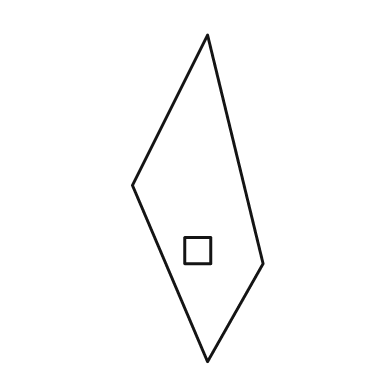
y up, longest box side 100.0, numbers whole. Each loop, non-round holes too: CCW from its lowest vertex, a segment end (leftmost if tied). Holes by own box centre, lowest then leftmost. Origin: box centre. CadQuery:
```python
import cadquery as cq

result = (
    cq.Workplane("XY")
    .moveTo(3.0, -50.0)
    .lineTo(20.0, -20.0)
    .lineTo(3.0, 50.0)
    .lineTo(-20.0, 4.0)
    .close()
    .moveTo(-4.0, -20.0)
    .lineTo(4.0, -20.0)
    .lineTo(4.0, -12.0)
    .lineTo(-4.0, -12.0)
    .close()
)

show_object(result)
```